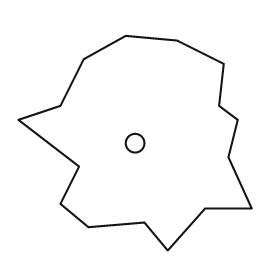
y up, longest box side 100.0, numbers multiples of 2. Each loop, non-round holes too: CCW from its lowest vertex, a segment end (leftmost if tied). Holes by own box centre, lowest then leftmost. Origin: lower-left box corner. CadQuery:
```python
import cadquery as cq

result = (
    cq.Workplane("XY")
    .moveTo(64.0, 0.0)
    .lineTo(80.0, 18.0)
    .lineTo(100.0, 18.0)
    .lineTo(90.0, 40.0)
    .lineTo(94.0, 56.0)
    .lineTo(86.0, 62.0)
    .lineTo(88.0, 80.0)
    .lineTo(68.0, 90.0)
    .lineTo(46.0, 92.0)
    .lineTo(28.0, 82.0)
    .lineTo(18.0, 62.0)
    .lineTo(0.0, 56.0)
    .lineTo(26.0, 36.0)
    .lineTo(18.0, 20.0)
    .lineTo(30.0, 10.0)
    .lineTo(54.0, 12.0)
    .close()
    .moveTo(50.0, 46.0)
    .circle(4.0)
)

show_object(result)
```